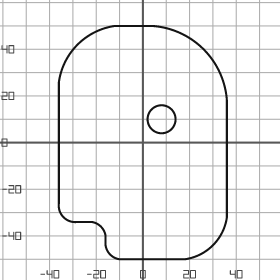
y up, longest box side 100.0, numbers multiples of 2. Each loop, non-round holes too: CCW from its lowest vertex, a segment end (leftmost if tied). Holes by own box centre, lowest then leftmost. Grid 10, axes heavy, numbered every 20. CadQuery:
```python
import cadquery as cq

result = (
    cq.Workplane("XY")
    .moveTo(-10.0, -50.0)
    .lineTo(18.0, -50.0)
    .threePointArc((30.0, -44.0), (36.0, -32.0))
    .lineTo(36.0, 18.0)
    .threePointArc((26.0, 40.0), (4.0, 50.0))
    .lineTo(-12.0, 50.0)
    .threePointArc((-28.0, 42.0), (-36.0, 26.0))
    .lineTo(-36.0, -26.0)
    .threePointArc((-34.0, -32.0), (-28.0, -34.0))
    .lineTo(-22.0, -34.0)
    .threePointArc((-18.0, -36.0), (-16.0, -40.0))
    .lineTo(-16.0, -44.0)
    .threePointArc((-14.0, -48.0), (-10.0, -50.0))
    .close()
    .moveTo(8.0, 10.0)
    .circle(6.0)
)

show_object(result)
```